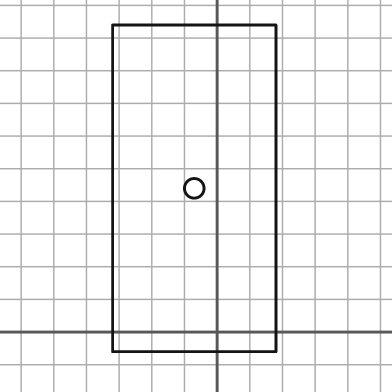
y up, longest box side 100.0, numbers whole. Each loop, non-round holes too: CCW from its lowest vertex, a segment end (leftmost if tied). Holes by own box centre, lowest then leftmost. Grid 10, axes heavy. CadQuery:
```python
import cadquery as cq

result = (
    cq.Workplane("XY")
    .moveTo(-32.0, -6.0)
    .lineTo(18.0, -6.0)
    .lineTo(18.0, 94.0)
    .lineTo(-32.0, 94.0)
    .close()
    .moveTo(-7.0, 44.0)
    .circle(3.0)
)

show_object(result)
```